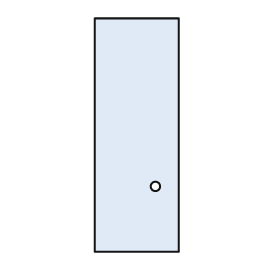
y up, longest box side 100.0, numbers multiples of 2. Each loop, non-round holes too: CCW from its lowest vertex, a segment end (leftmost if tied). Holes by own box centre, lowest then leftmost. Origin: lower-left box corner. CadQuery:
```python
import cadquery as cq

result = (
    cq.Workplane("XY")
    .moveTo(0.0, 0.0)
    .lineTo(36.0, 0.0)
    .lineTo(36.0, 100.0)
    .lineTo(0.0, 100.0)
    .close()
    .moveTo(26.0, 28.0)
    .circle(2.0)
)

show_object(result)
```